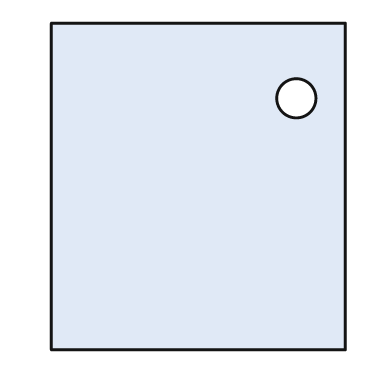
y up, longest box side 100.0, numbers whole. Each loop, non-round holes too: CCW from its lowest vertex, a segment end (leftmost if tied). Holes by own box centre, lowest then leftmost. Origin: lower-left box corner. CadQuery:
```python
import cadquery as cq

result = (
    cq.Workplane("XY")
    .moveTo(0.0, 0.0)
    .lineTo(90.0, 0.0)
    .lineTo(90.0, 100.0)
    .lineTo(0.0, 100.0)
    .close()
    .moveTo(75.0, 77.0)
    .circle(6.0)
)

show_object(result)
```